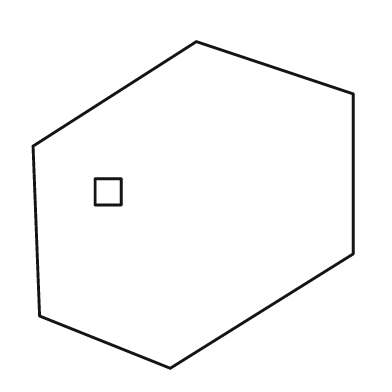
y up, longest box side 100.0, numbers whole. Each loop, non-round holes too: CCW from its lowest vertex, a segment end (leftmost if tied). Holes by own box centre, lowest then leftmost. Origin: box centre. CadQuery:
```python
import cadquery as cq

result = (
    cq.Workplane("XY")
    .moveTo(-7.0, -50.0)
    .lineTo(49.0, -15.0)
    .lineTo(49.0, 34.0)
    .lineTo(1.0, 50.0)
    .lineTo(-49.0, 18.0)
    .lineTo(-47.0, -34.0)
    .close()
    .moveTo(-30.0, 0.0)
    .lineTo(-22.0, 0.0)
    .lineTo(-22.0, 8.0)
    .lineTo(-30.0, 8.0)
    .close()
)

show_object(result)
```